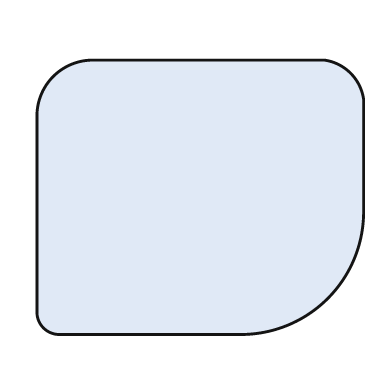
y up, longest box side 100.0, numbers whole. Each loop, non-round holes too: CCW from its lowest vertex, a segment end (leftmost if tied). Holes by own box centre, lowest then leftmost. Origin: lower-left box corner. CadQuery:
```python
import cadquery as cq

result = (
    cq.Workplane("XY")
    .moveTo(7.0, 0.0)
    .lineTo(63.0, 0.0)
    .threePointArc((89.0, 11.0), (100.0, 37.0))
    .lineTo(100.0, 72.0)
    .threePointArc((96.0, 80.0), (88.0, 84.0))
    .lineTo(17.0, 84.0)
    .threePointArc((5.0, 79.0), (0.0, 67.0))
    .lineTo(0.0, 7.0)
    .threePointArc((2.0, 2.0), (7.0, 0.0))
    .close()
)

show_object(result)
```